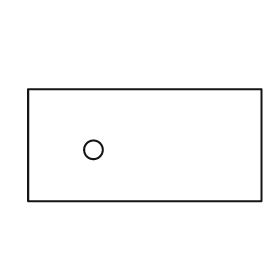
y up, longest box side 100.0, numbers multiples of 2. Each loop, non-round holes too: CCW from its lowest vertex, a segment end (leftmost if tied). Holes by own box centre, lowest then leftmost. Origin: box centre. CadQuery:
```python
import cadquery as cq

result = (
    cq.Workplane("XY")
    .moveTo(-50.0, -24.0)
    .lineTo(50.0, -24.0)
    .lineTo(50.0, 24.0)
    .lineTo(-50.0, 24.0)
    .close()
    .moveTo(-22.0, -2.0)
    .circle(4.0)
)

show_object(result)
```